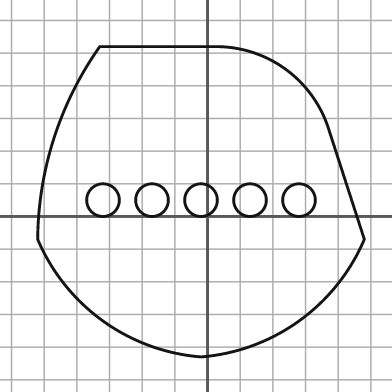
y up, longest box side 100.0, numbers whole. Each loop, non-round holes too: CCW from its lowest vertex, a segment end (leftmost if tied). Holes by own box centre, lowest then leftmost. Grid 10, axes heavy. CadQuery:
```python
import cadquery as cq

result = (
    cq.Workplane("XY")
    .moveTo(-2.0, -43.0)
    .threePointArc((28.0, -32.0), (48.0, -7.0))
    .lineTo(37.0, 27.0)
    .threePointArc((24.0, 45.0), (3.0, 52.0))
    .lineTo(-33.0, 52.0)
    .threePointArc((-47.0, 24.0), (-52.0, -7.0))
    .threePointArc((-32.0, -32.0), (-2.0, -43.0))
    .close()
    .moveTo(-32.0, 5.0)
    .circle(5.0)
    .moveTo(-17.0, 5.0)
    .circle(5.0)
    .moveTo(-2.0, 5.0)
    .circle(5.0)
    .moveTo(13.0, 5.0)
    .circle(5.0)
    .moveTo(28.0, 5.0)
    .circle(5.0)
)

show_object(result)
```